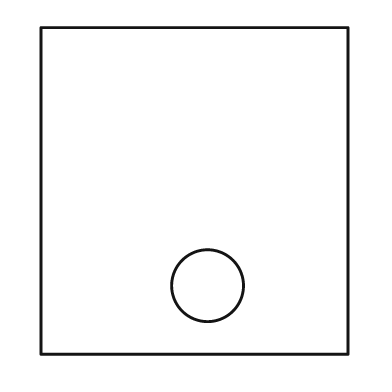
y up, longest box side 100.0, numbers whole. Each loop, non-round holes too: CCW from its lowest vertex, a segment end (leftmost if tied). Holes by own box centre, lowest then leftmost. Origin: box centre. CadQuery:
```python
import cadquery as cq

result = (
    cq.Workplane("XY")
    .moveTo(-47.0, -50.0)
    .lineTo(47.0, -50.0)
    .lineTo(47.0, 50.0)
    .lineTo(-47.0, 50.0)
    .close()
    .moveTo(4.0, -29.0)
    .circle(11.0)
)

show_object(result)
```